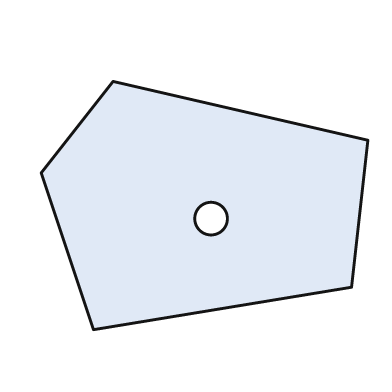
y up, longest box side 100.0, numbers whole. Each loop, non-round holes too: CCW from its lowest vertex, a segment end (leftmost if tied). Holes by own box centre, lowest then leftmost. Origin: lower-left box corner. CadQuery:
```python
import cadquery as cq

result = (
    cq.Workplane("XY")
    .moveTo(16.0, 0.0)
    .lineTo(95.0, 13.0)
    .lineTo(100.0, 58.0)
    .lineTo(22.0, 76.0)
    .lineTo(0.0, 48.0)
    .close()
    .moveTo(52.0, 34.0)
    .circle(5.0)
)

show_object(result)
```